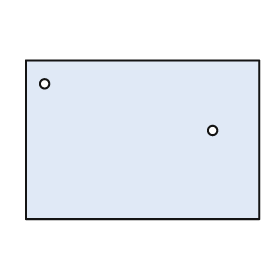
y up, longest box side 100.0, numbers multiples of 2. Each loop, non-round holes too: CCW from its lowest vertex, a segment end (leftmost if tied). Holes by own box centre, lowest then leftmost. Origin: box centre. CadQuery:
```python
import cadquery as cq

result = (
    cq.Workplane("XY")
    .moveTo(-50.0, -34.0)
    .lineTo(50.0, -34.0)
    .lineTo(50.0, 34.0)
    .lineTo(-50.0, 34.0)
    .close()
    .moveTo(30.0, 4.0)
    .circle(2.0)
    .moveTo(-42.0, 24.0)
    .circle(2.0)
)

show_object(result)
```